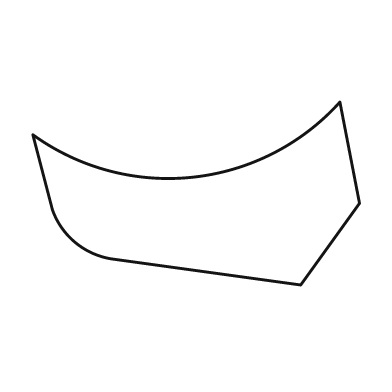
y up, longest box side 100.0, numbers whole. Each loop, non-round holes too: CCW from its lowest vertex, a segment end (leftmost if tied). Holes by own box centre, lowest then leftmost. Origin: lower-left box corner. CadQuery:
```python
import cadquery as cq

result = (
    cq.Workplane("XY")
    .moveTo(82.0, 0.0)
    .lineTo(100.0, 25.0)
    .lineTo(94.0, 56.0)
    .threePointArc((49.0, 33.0), (0.0, 46.0))
    .lineTo(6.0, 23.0)
    .threePointArc((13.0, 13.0), (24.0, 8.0))
    .close()
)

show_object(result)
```